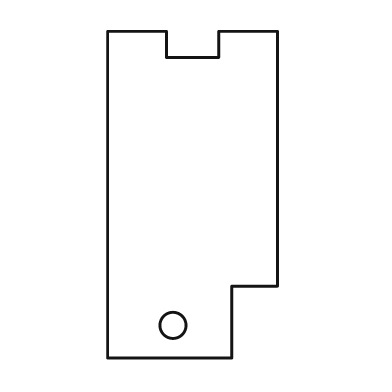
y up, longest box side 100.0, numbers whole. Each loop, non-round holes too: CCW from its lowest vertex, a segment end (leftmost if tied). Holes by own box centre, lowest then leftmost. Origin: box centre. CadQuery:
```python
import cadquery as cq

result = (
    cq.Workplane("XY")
    .moveTo(-26.0, -50.0)
    .lineTo(12.0, -50.0)
    .lineTo(12.0, -28.0)
    .lineTo(26.0, -28.0)
    .lineTo(26.0, 50.0)
    .lineTo(8.0, 50.0)
    .lineTo(8.0, 42.0)
    .lineTo(-8.0, 42.0)
    .lineTo(-8.0, 50.0)
    .lineTo(-26.0, 50.0)
    .close()
    .moveTo(-6.0, -40.0)
    .circle(4.0)
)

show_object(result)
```